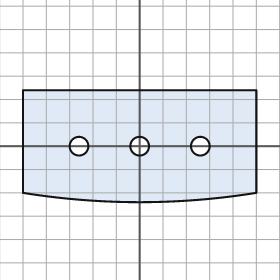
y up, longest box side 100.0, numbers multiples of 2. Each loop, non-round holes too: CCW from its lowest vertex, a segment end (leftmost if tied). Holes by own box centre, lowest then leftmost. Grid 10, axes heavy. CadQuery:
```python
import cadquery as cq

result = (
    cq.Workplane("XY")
    .moveTo(-50.0, -20.0)
    .threePointArc((0.0, -24.0), (50.0, -20.0))
    .lineTo(50.0, 24.0)
    .lineTo(-50.0, 24.0)
    .close()
    .moveTo(-26.0, 0.0)
    .circle(4.0)
    .moveTo(0.0, 0.0)
    .circle(4.0)
    .moveTo(26.0, 0.0)
    .circle(4.0)
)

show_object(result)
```